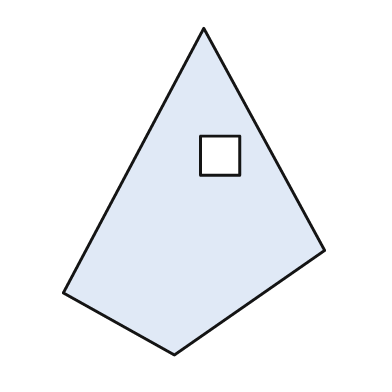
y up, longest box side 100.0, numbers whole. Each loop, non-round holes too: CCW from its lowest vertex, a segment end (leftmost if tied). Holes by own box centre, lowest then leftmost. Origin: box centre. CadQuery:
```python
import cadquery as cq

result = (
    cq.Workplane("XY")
    .moveTo(-6.0, -50.0)
    .lineTo(40.0, -18.0)
    .lineTo(3.0, 50.0)
    .lineTo(-40.0, -31.0)
    .close()
    .moveTo(2.0, 5.0)
    .lineTo(14.0, 5.0)
    .lineTo(14.0, 17.0)
    .lineTo(2.0, 17.0)
    .close()
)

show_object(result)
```